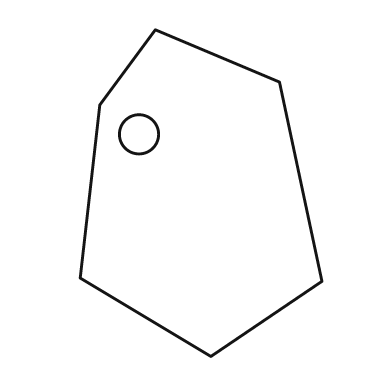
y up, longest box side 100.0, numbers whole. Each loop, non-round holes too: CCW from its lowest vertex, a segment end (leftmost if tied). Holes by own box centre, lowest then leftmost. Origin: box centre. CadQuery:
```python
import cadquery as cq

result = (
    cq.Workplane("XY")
    .moveTo(3.0, -50.0)
    .lineTo(37.0, -27.0)
    .lineTo(24.0, 34.0)
    .lineTo(-14.0, 50.0)
    .lineTo(-31.0, 27.0)
    .lineTo(-37.0, -26.0)
    .close()
    .moveTo(-19.0, 18.0)
    .circle(6.0)
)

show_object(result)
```